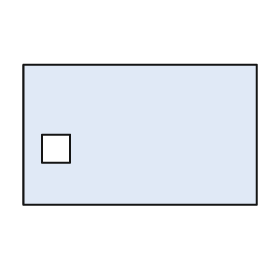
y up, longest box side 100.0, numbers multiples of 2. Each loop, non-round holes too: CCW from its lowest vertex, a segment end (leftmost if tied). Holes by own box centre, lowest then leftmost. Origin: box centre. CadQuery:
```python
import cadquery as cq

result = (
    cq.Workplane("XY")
    .moveTo(-50.0, -30.0)
    .lineTo(50.0, -30.0)
    .lineTo(50.0, 30.0)
    .lineTo(-50.0, 30.0)
    .close()
    .moveTo(-42.0, -12.0)
    .lineTo(-30.0, -12.0)
    .lineTo(-30.0, 0.0)
    .lineTo(-42.0, 0.0)
    .close()
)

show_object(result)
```